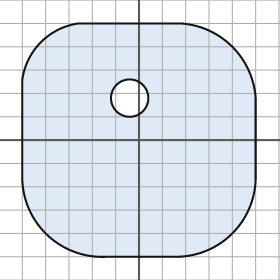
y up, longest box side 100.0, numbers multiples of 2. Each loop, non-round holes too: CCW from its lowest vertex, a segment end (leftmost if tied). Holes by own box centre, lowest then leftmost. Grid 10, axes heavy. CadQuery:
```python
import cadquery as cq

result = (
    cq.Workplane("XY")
    .moveTo(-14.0, -50.0)
    .lineTo(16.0, -50.0)
    .threePointArc((40.0, -40.0), (50.0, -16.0))
    .lineTo(50.0, 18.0)
    .threePointArc((40.0, 40.0), (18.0, 50.0))
    .lineTo(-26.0, 50.0)
    .threePointArc((-42.0, 42.0), (-50.0, 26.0))
    .lineTo(-50.0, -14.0)
    .threePointArc((-40.0, -40.0), (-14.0, -50.0))
    .close()
    .moveTo(-4.0, 18.0)
    .circle(8.0)
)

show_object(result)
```